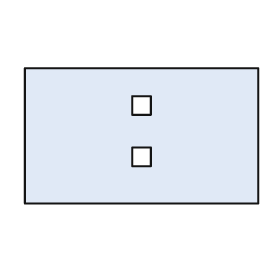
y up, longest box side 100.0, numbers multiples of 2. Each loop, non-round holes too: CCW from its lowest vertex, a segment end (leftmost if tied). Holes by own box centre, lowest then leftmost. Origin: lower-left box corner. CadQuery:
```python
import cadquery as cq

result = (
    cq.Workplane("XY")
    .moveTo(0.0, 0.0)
    .lineTo(100.0, 0.0)
    .lineTo(100.0, 58.0)
    .lineTo(0.0, 58.0)
    .close()
    .moveTo(46.0, 16.0)
    .lineTo(54.0, 16.0)
    .lineTo(54.0, 24.0)
    .lineTo(46.0, 24.0)
    .close()
    .moveTo(46.0, 38.0)
    .lineTo(54.0, 38.0)
    .lineTo(54.0, 46.0)
    .lineTo(46.0, 46.0)
    .close()
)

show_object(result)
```